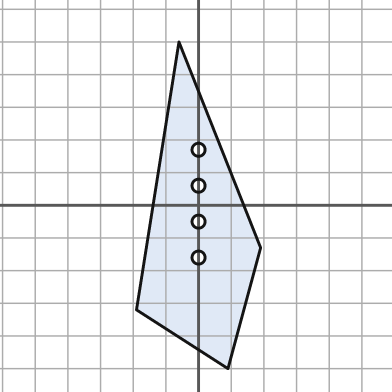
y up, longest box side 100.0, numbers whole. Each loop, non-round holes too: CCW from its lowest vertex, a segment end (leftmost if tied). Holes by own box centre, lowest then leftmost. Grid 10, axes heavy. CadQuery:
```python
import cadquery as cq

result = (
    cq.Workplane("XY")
    .moveTo(9.0, -50.0)
    .lineTo(19.0, -13.0)
    .lineTo(-6.0, 50.0)
    .lineTo(-19.0, -32.0)
    .close()
    .moveTo(0.0, -16.0)
    .circle(2.0)
    .moveTo(0.0, -5.0)
    .circle(2.0)
    .moveTo(0.0, 6.0)
    .circle(2.0)
    .moveTo(0.0, 17.0)
    .circle(2.0)
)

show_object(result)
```